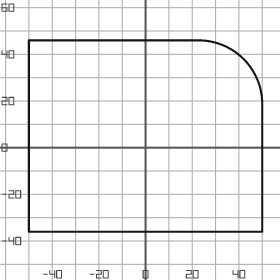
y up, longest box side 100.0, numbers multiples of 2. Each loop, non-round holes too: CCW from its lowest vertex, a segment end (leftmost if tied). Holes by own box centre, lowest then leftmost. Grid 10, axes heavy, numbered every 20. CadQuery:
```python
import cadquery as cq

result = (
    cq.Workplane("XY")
    .moveTo(-50.0, -36.0)
    .lineTo(50.0, -36.0)
    .lineTo(50.0, 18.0)
    .threePointArc((42.0, 38.0), (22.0, 46.0))
    .lineTo(-50.0, 46.0)
    .close()
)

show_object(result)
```